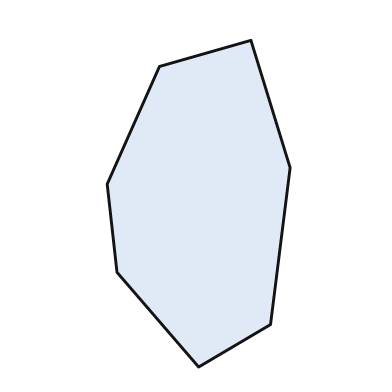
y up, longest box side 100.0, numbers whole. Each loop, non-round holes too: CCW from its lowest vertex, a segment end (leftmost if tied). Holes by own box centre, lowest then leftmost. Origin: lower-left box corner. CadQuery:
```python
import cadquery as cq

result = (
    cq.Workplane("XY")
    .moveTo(28.0, 0.0)
    .lineTo(50.0, 13.0)
    .lineTo(56.0, 61.0)
    .lineTo(44.0, 100.0)
    .lineTo(16.0, 92.0)
    .lineTo(0.0, 56.0)
    .lineTo(3.0, 29.0)
    .close()
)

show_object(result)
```